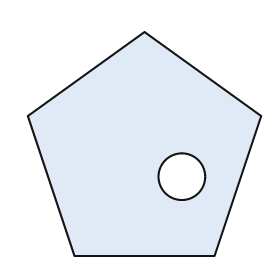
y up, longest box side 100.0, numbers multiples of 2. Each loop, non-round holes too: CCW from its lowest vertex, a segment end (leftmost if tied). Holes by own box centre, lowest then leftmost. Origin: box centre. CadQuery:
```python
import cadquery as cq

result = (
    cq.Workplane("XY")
    .moveTo(-30.0, -48.0)
    .lineTo(30.0, -48.0)
    .lineTo(50.0, 12.0)
    .lineTo(0.0, 48.0)
    .lineTo(-50.0, 12.0)
    .close()
    .moveTo(16.0, -14.0)
    .circle(10.0)
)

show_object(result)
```